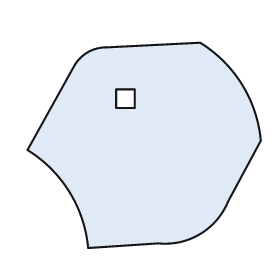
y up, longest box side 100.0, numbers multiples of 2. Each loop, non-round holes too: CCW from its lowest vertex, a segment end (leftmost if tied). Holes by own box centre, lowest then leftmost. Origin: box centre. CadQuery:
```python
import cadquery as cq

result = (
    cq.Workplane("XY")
    .moveTo(-24.0, -44.0)
    .lineTo(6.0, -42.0)
    .threePointArc((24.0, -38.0), (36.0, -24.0))
    .lineTo(50.0, 2.0)
    .threePointArc((42.0, 26.0), (24.0, 44.0))
    .lineTo(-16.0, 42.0)
    .threePointArc((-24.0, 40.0), (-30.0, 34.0))
    .lineTo(-50.0, -2.0)
    .threePointArc((-32.0, -20.0), (-24.0, -44.0))
    .close()
    .moveTo(-12.0, 16.0)
    .lineTo(-4.0, 16.0)
    .lineTo(-4.0, 24.0)
    .lineTo(-12.0, 24.0)
    .close()
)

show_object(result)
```